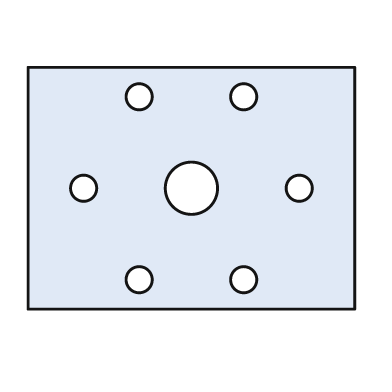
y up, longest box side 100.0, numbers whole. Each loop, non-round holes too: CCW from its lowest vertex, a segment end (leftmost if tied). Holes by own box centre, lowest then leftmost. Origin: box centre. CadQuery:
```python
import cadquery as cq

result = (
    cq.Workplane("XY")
    .moveTo(-50.0, -37.0)
    .lineTo(50.0, -37.0)
    .lineTo(50.0, 37.0)
    .lineTo(-50.0, 37.0)
    .close()
    .moveTo(-16.0, -28.0)
    .circle(4.0)
    .moveTo(16.0, -28.0)
    .circle(4.0)
    .moveTo(-33.0, 0.0)
    .circle(4.0)
    .moveTo(0.0, 0.0)
    .circle(8.0)
    .moveTo(33.0, 0.0)
    .circle(4.0)
    .moveTo(-16.0, 28.0)
    .circle(4.0)
    .moveTo(16.0, 28.0)
    .circle(4.0)
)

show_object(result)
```